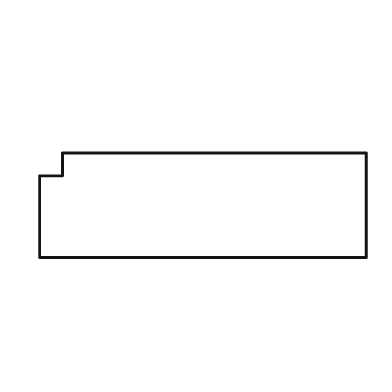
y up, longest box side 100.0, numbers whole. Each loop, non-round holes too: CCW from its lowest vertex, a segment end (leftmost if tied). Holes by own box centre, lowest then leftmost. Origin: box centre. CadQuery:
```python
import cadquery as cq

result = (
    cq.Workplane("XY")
    .moveTo(-50.0, -16.0)
    .lineTo(50.0, -16.0)
    .lineTo(50.0, 16.0)
    .lineTo(-43.0, 16.0)
    .lineTo(-43.0, 9.0)
    .lineTo(-50.0, 9.0)
    .close()
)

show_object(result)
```